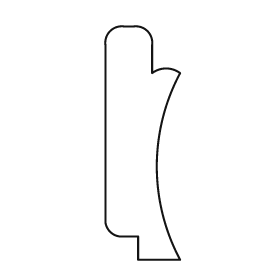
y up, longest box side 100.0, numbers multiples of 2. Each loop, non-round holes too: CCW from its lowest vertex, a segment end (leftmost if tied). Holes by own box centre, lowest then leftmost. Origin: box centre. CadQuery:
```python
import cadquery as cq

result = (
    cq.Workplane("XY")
    .moveTo(-2.0, -50.0)
    .lineTo(16.0, -50.0)
    .threePointArc((6.0, -10.0), (16.0, 30.0))
    .threePointArc((10.0, 32.0), (4.0, 30.0))
    .lineTo(4.0, 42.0)
    .threePointArc((2.0, 48.0), (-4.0, 50.0))
    .lineTo(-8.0, 50.0)
    .threePointArc((-14.0, 48.0), (-16.0, 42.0))
    .lineTo(-16.0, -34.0)
    .threePointArc((-14.0, -38.0), (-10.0, -40.0))
    .lineTo(-2.0, -40.0)
    .close()
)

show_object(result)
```